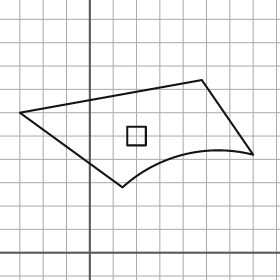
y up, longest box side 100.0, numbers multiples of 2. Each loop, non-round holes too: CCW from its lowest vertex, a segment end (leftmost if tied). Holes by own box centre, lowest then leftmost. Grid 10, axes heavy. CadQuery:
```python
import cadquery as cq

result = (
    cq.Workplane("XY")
    .moveTo(14.0, 28.0)
    .threePointArc((40.0, 42.0), (70.0, 42.0))
    .lineTo(48.0, 74.0)
    .lineTo(-30.0, 60.0)
    .close()
    .moveTo(16.0, 46.0)
    .lineTo(24.0, 46.0)
    .lineTo(24.0, 54.0)
    .lineTo(16.0, 54.0)
    .close()
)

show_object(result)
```